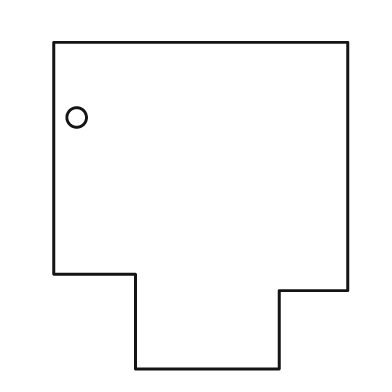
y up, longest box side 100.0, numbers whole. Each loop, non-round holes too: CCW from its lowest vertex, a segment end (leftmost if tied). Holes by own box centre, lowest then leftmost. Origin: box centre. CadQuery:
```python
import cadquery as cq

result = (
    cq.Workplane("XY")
    .moveTo(-20.0, -50.0)
    .lineTo(24.0, -50.0)
    .lineTo(24.0, -26.0)
    .lineTo(45.0, -26.0)
    .lineTo(45.0, 50.0)
    .lineTo(-45.0, 50.0)
    .lineTo(-45.0, -21.0)
    .lineTo(-20.0, -21.0)
    .close()
    .moveTo(-38.0, 27.0)
    .circle(3.0)
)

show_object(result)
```